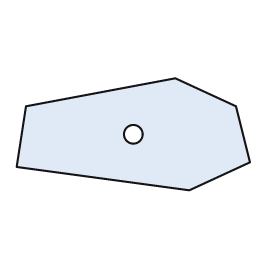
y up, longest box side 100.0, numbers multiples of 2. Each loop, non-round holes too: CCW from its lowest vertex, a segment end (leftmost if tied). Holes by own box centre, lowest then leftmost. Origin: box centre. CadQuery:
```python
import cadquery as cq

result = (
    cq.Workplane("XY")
    .moveTo(24.0, -24.0)
    .lineTo(50.0, -12.0)
    .lineTo(44.0, 12.0)
    .lineTo(18.0, 24.0)
    .lineTo(-46.0, 12.0)
    .lineTo(-50.0, -14.0)
    .close()
    .moveTo(0.0, 0.0)
    .circle(4.0)
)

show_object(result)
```